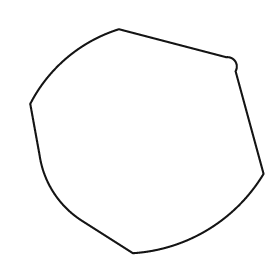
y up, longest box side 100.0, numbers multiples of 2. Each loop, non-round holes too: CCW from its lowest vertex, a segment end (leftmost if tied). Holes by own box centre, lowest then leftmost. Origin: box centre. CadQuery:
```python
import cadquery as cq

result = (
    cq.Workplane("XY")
    .moveTo(-6.0, -48.0)
    .threePointArc((26.0, -38.0), (50.0, -14.0))
    .lineTo(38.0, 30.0)
    .threePointArc((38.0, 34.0), (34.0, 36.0))
    .lineTo(-12.0, 48.0)
    .threePointArc((-34.0, 36.0), (-50.0, 16.0))
    .lineTo(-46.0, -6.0)
    .threePointArc((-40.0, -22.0), (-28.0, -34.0))
    .close()
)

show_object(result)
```